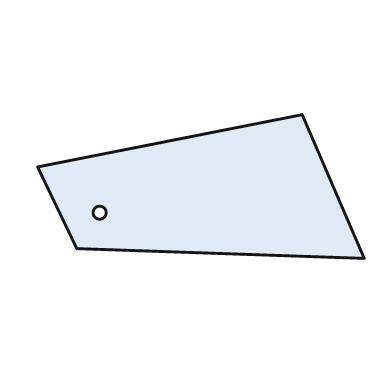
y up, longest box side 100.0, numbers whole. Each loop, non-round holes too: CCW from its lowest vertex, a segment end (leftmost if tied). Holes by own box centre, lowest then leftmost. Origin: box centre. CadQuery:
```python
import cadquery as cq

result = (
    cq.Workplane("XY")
    .moveTo(50.0, -22.0)
    .lineTo(31.0, 22.0)
    .lineTo(-50.0, 6.0)
    .lineTo(-38.0, -19.0)
    .close()
    .moveTo(-31.0, -8.0)
    .circle(2.0)
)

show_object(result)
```